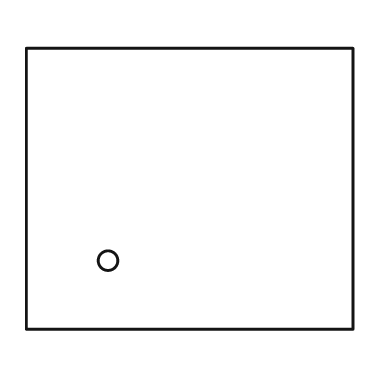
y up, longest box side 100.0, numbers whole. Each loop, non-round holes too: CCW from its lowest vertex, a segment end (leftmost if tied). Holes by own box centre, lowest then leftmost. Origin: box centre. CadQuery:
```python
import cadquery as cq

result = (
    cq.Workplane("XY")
    .moveTo(-50.0, -43.0)
    .lineTo(50.0, -43.0)
    .lineTo(50.0, 43.0)
    .lineTo(-50.0, 43.0)
    .close()
    .moveTo(-25.0, -22.0)
    .circle(3.0)
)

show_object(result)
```